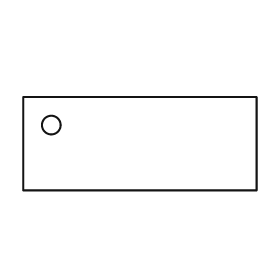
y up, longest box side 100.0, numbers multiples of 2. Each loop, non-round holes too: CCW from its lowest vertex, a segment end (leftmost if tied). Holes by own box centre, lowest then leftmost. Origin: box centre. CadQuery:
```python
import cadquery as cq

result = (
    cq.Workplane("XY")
    .moveTo(-50.0, -20.0)
    .lineTo(50.0, -20.0)
    .lineTo(50.0, 20.0)
    .lineTo(-50.0, 20.0)
    .close()
    .moveTo(-38.0, 8.0)
    .circle(4.0)
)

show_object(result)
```